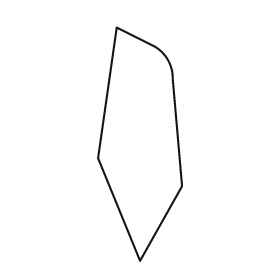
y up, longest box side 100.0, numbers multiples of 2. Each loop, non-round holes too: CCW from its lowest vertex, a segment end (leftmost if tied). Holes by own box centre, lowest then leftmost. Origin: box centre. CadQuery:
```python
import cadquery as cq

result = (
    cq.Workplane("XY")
    .moveTo(0.0, -50.0)
    .lineTo(18.0, -18.0)
    .lineTo(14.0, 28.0)
    .threePointArc((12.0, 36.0), (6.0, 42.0))
    .lineTo(-10.0, 50.0)
    .lineTo(-18.0, -6.0)
    .close()
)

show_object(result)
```